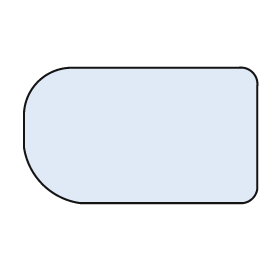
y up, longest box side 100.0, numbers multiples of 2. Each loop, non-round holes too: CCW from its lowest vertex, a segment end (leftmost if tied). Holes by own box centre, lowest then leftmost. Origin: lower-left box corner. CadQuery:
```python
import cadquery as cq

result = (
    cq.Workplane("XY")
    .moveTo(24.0, 0.0)
    .lineTo(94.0, 0.0)
    .threePointArc((98.0, 2.0), (100.0, 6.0))
    .lineTo(100.0, 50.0)
    .threePointArc((98.0, 56.0), (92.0, 58.0))
    .lineTo(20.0, 58.0)
    .threePointArc((6.0, 52.0), (0.0, 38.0))
    .lineTo(0.0, 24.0)
    .threePointArc((8.0, 8.0), (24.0, 0.0))
    .close()
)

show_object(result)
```